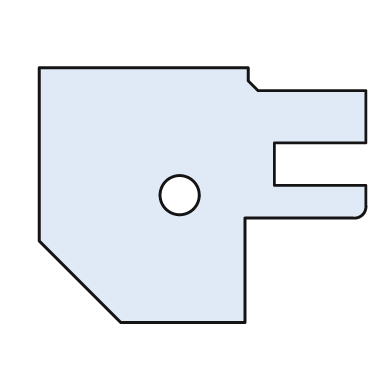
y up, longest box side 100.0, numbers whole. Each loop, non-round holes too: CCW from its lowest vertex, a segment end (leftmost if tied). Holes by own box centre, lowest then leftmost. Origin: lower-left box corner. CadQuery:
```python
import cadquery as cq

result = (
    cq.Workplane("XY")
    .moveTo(25.0, 0.0)
    .lineTo(63.0, 0.0)
    .lineTo(63.0, 32.0)
    .lineTo(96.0, 32.0)
    .threePointArc((99.0, 33.0), (100.0, 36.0))
    .lineTo(100.0, 42.0)
    .lineTo(72.0, 42.0)
    .lineTo(72.0, 55.0)
    .lineTo(100.0, 55.0)
    .lineTo(100.0, 71.0)
    .lineTo(67.0, 71.0)
    .lineTo(64.0, 74.0)
    .lineTo(64.0, 78.0)
    .lineTo(0.0, 78.0)
    .lineTo(0.0, 25.0)
    .close()
    .moveTo(43.0, 39.0)
    .circle(6.0)
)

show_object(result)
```